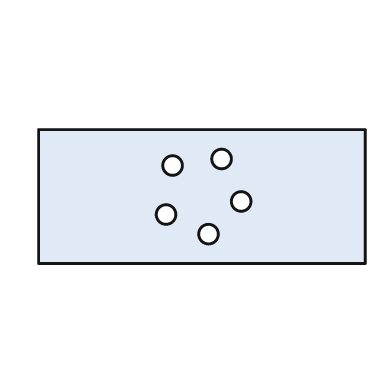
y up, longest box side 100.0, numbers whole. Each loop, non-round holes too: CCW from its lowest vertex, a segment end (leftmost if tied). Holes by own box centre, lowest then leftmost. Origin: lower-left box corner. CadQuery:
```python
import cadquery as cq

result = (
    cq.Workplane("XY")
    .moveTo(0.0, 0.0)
    .lineTo(100.0, 0.0)
    .lineTo(100.0, 41.0)
    .lineTo(0.0, 41.0)
    .close()
    .moveTo(52.0, 9.0)
    .circle(3.0)
    .moveTo(39.0, 15.0)
    .circle(3.0)
    .moveTo(62.0, 19.0)
    .circle(3.0)
    .moveTo(41.0, 30.0)
    .circle(3.0)
    .moveTo(56.0, 32.0)
    .circle(3.0)
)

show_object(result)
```